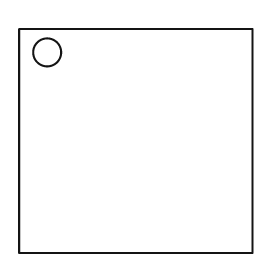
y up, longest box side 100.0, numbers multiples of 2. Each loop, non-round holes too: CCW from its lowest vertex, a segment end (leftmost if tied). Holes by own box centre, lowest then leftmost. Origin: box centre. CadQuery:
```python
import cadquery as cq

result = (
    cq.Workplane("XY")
    .moveTo(-50.0, -48.0)
    .lineTo(50.0, -48.0)
    .lineTo(50.0, 48.0)
    .lineTo(-50.0, 48.0)
    .close()
    .moveTo(-38.0, 38.0)
    .circle(6.0)
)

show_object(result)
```